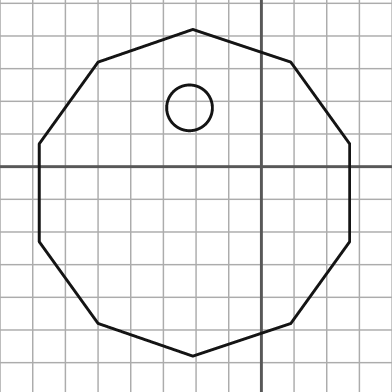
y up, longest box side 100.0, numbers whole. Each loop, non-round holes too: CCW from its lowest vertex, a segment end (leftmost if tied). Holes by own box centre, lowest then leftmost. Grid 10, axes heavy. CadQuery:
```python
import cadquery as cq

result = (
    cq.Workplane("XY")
    .moveTo(-21.0, -58.0)
    .lineTo(9.0, -48.0)
    .lineTo(27.0, -23.0)
    .lineTo(27.0, 7.0)
    .lineTo(9.0, 32.0)
    .lineTo(-21.0, 42.0)
    .lineTo(-50.0, 32.0)
    .lineTo(-68.0, 7.0)
    .lineTo(-68.0, -23.0)
    .lineTo(-50.0, -48.0)
    .close()
    .moveTo(-22.0, 18.0)
    .circle(7.0)
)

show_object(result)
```